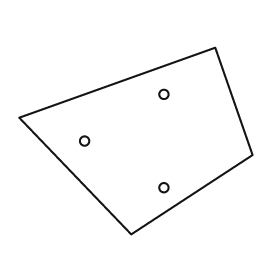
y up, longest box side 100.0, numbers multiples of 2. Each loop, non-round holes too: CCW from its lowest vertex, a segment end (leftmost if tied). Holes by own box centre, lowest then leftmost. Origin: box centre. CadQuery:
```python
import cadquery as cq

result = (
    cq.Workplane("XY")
    .moveTo(-2.0, -40.0)
    .lineTo(50.0, -6.0)
    .lineTo(34.0, 40.0)
    .lineTo(-50.0, 10.0)
    .close()
    .moveTo(12.0, -20.0)
    .circle(2.0)
    .moveTo(-22.0, 0.0)
    .circle(2.0)
    .moveTo(12.0, 20.0)
    .circle(2.0)
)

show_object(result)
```